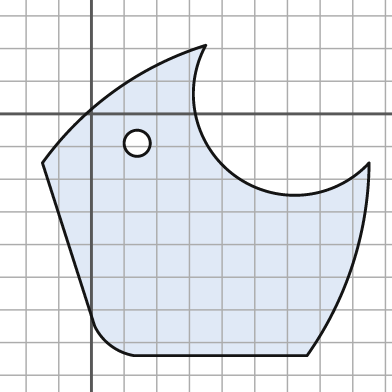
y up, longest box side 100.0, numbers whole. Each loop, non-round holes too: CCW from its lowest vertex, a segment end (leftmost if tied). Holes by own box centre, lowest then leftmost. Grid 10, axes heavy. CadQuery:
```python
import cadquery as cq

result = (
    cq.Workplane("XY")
    .moveTo(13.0, -74.0)
    .lineTo(66.0, -74.0)
    .threePointArc((80.0, -46.0), (85.0, -15.0))
    .threePointArc((44.0, -19.0), (35.0, 21.0))
    .threePointArc((7.0, 7.0), (-15.0, -15.0))
    .lineTo(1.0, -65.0)
    .threePointArc((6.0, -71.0), (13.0, -74.0))
    .close()
    .moveTo(14.0, -9.0)
    .circle(4.0)
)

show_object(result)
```